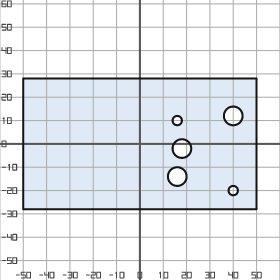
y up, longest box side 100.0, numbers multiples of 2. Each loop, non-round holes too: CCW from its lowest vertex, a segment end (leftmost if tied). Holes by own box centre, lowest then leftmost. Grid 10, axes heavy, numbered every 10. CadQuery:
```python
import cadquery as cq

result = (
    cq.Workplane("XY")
    .moveTo(-50.0, -28.0)
    .lineTo(50.0, -28.0)
    .lineTo(50.0, 28.0)
    .lineTo(-50.0, 28.0)
    .close()
    .moveTo(40.0, -20.0)
    .circle(2.0)
    .moveTo(16.0, -14.0)
    .circle(4.0)
    .moveTo(18.0, -2.0)
    .circle(4.0)
    .moveTo(16.0, 10.0)
    .circle(2.0)
    .moveTo(40.0, 12.0)
    .circle(4.0)
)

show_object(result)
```